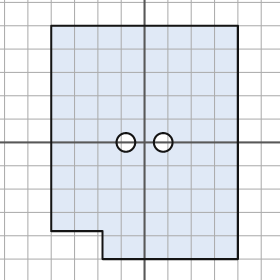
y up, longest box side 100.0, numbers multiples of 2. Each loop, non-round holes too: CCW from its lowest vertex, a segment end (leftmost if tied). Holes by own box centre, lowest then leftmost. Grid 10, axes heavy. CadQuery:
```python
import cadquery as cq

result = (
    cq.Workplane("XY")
    .moveTo(-18.0, -50.0)
    .lineTo(40.0, -50.0)
    .lineTo(40.0, 50.0)
    .lineTo(-40.0, 50.0)
    .lineTo(-40.0, -38.0)
    .lineTo(-18.0, -38.0)
    .close()
    .moveTo(-8.0, 0.0)
    .circle(4.0)
    .moveTo(8.0, 0.0)
    .circle(4.0)
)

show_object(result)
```